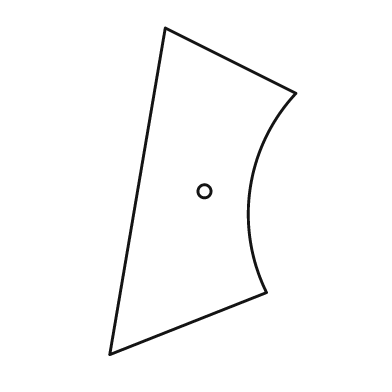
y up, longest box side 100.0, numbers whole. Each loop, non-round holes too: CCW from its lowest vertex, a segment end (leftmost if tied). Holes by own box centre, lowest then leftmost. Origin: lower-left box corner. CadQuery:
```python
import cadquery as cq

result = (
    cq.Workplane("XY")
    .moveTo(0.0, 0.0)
    .lineTo(48.0, 19.0)
    .threePointArc((43.0, 51.0), (57.0, 80.0))
    .lineTo(17.0, 100.0)
    .close()
    .moveTo(29.0, 50.0)
    .circle(2.0)
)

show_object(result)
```